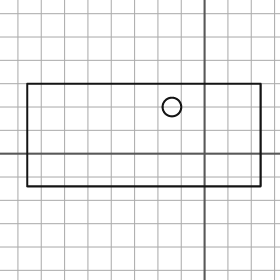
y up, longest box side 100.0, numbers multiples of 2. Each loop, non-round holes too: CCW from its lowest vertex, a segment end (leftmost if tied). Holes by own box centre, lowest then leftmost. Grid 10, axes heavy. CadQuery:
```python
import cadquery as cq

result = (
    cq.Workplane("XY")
    .moveTo(-76.0, -14.0)
    .lineTo(24.0, -14.0)
    .lineTo(24.0, 30.0)
    .lineTo(-76.0, 30.0)
    .close()
    .moveTo(-14.0, 20.0)
    .circle(4.0)
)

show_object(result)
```